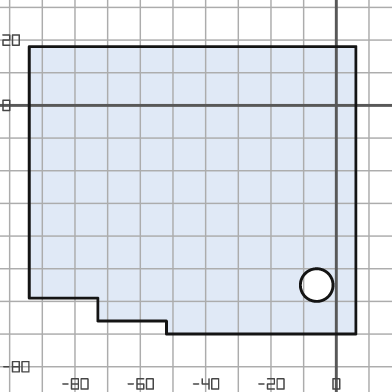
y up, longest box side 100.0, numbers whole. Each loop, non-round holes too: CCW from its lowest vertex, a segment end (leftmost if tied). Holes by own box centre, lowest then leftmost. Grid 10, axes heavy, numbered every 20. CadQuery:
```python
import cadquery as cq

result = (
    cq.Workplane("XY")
    .moveTo(-52.0, -70.0)
    .lineTo(6.0, -70.0)
    .lineTo(6.0, 18.0)
    .lineTo(-94.0, 18.0)
    .lineTo(-94.0, -59.0)
    .lineTo(-73.0, -59.0)
    .lineTo(-73.0, -66.0)
    .lineTo(-52.0, -66.0)
    .close()
    .moveTo(-6.0, -55.0)
    .circle(5.0)
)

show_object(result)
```